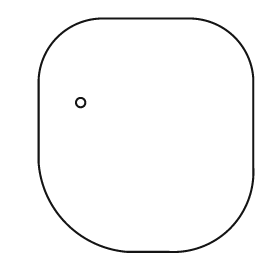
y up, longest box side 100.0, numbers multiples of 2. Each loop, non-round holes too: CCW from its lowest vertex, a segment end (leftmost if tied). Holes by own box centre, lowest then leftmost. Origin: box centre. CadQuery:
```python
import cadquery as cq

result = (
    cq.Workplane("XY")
    .moveTo(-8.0, -50.0)
    .lineTo(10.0, -50.0)
    .threePointArc((36.0, -40.0), (46.0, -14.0))
    .lineTo(46.0, 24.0)
    .threePointArc((38.0, 42.0), (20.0, 50.0))
    .lineTo(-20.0, 50.0)
    .threePointArc((-38.0, 42.0), (-46.0, 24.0))
    .lineTo(-46.0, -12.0)
    .threePointArc((-34.0, -38.0), (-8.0, -50.0))
    .close()
    .moveTo(-28.0, 14.0)
    .circle(2.0)
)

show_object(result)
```